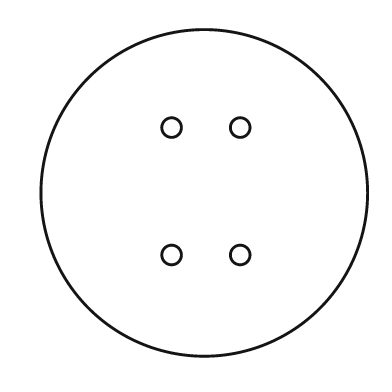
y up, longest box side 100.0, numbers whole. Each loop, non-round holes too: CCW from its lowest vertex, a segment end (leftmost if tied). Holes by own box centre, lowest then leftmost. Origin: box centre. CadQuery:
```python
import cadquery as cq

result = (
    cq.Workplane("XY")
    .moveTo(0.0, 0.0)
    .circle(50.0)
    .moveTo(-10.0, -19.0)
    .circle(3.0)
    .moveTo(11.0, -19.0)
    .circle(3.0)
    .moveTo(-10.0, 20.0)
    .circle(3.0)
    .moveTo(11.0, 20.0)
    .circle(3.0)
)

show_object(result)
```